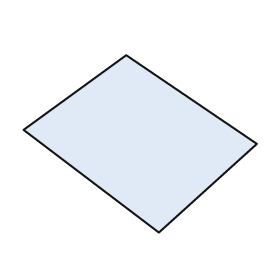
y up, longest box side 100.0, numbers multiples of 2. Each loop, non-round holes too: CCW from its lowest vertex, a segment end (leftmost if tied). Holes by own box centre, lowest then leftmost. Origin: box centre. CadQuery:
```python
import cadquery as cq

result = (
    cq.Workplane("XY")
    .moveTo(8.0, -38.0)
    .lineTo(50.0, 0.0)
    .lineTo(-6.0, 38.0)
    .lineTo(-50.0, 6.0)
    .close()
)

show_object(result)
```